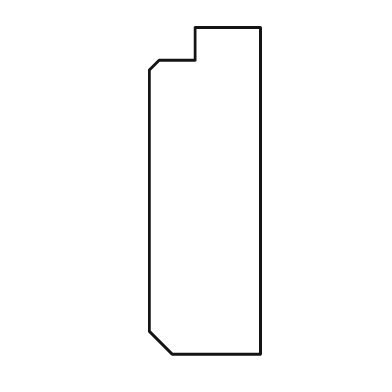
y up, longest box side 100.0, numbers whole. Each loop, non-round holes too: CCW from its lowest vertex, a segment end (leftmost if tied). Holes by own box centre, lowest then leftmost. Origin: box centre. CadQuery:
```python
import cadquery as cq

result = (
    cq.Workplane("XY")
    .moveTo(-10.0, -50.0)
    .lineTo(17.0, -50.0)
    .lineTo(17.0, 50.0)
    .lineTo(-3.0, 50.0)
    .lineTo(-3.0, 40.0)
    .lineTo(-14.0, 40.0)
    .lineTo(-17.0, 37.0)
    .lineTo(-17.0, -43.0)
    .close()
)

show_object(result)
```